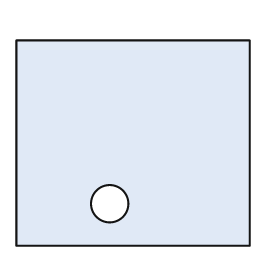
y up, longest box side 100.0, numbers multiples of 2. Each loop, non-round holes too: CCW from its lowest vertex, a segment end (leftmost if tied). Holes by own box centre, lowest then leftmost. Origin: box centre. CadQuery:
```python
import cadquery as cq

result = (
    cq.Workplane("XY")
    .moveTo(-50.0, -44.0)
    .lineTo(50.0, -44.0)
    .lineTo(50.0, 44.0)
    .lineTo(-50.0, 44.0)
    .close()
    .moveTo(-10.0, -26.0)
    .circle(8.0)
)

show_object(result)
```